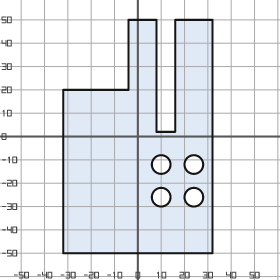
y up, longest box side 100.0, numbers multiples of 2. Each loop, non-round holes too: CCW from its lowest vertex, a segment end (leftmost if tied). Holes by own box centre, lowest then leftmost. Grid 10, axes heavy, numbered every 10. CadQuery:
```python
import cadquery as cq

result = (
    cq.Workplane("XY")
    .moveTo(-32.0, -50.0)
    .lineTo(32.0, -50.0)
    .lineTo(32.0, 50.0)
    .lineTo(16.0, 50.0)
    .lineTo(16.0, 2.0)
    .lineTo(8.0, 2.0)
    .lineTo(8.0, 50.0)
    .lineTo(-4.0, 50.0)
    .lineTo(-4.0, 20.0)
    .lineTo(-32.0, 20.0)
    .close()
    .moveTo(10.0, -26.0)
    .circle(4.0)
    .moveTo(24.0, -26.0)
    .circle(4.0)
    .moveTo(10.0, -12.0)
    .circle(4.0)
    .moveTo(24.0, -12.0)
    .circle(4.0)
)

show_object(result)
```